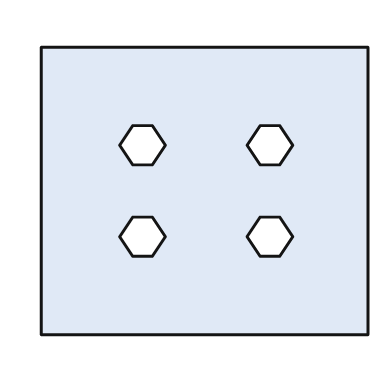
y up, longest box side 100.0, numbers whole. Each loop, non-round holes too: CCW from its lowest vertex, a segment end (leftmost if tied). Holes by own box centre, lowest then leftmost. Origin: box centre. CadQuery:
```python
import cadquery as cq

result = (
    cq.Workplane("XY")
    .moveTo(-50.0, -44.0)
    .lineTo(50.0, -44.0)
    .lineTo(50.0, 44.0)
    .lineTo(-50.0, 44.0)
    .close()
    .moveTo(-22.0, -20.0)
    .lineTo(-16.0, -20.0)
    .lineTo(-12.0, -14.0)
    .lineTo(-16.0, -8.0)
    .lineTo(-22.0, -8.0)
    .lineTo(-26.0, -14.0)
    .close()
    .moveTo(17.0, -20.0)
    .lineTo(23.0, -20.0)
    .lineTo(27.0, -14.0)
    .lineTo(23.0, -8.0)
    .lineTo(17.0, -8.0)
    .lineTo(13.0, -14.0)
    .close()
    .moveTo(-22.0, 8.0)
    .lineTo(-16.0, 8.0)
    .lineTo(-12.0, 14.0)
    .lineTo(-16.0, 20.0)
    .lineTo(-22.0, 20.0)
    .lineTo(-26.0, 14.0)
    .close()
    .moveTo(17.0, 8.0)
    .lineTo(23.0, 8.0)
    .lineTo(27.0, 14.0)
    .lineTo(23.0, 20.0)
    .lineTo(17.0, 20.0)
    .lineTo(13.0, 14.0)
    .close()
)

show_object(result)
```